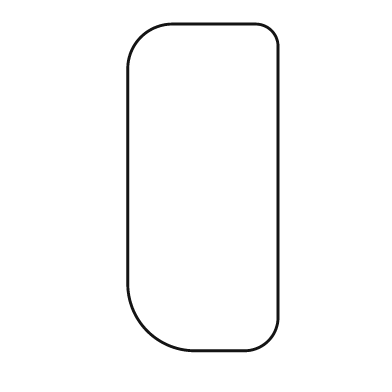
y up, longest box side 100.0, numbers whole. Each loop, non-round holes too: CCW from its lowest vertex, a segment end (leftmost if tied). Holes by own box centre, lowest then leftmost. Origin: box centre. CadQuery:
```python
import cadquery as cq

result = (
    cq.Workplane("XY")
    .moveTo(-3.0, -50.0)
    .lineTo(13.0, -50.0)
    .threePointArc((20.0, -47.0), (23.0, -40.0))
    .lineTo(23.0, 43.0)
    .threePointArc((21.0, 48.0), (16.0, 50.0))
    .lineTo(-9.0, 50.0)
    .threePointArc((-19.0, 46.0), (-23.0, 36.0))
    .lineTo(-23.0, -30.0)
    .threePointArc((-17.0, -44.0), (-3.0, -50.0))
    .close()
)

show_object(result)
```